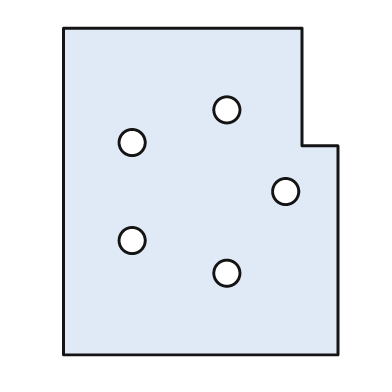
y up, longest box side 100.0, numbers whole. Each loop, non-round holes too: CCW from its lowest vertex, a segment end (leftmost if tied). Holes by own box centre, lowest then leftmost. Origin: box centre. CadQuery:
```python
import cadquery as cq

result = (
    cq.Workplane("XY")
    .moveTo(-42.0, -50.0)
    .lineTo(42.0, -50.0)
    .lineTo(42.0, 14.0)
    .lineTo(31.0, 14.0)
    .lineTo(31.0, 50.0)
    .lineTo(-42.0, 50.0)
    .close()
    .moveTo(8.0, -25.0)
    .circle(4.0)
    .moveTo(-21.0, -15.0)
    .circle(4.0)
    .moveTo(26.0, 0.0)
    .circle(4.0)
    .moveTo(-21.0, 15.0)
    .circle(4.0)
    .moveTo(8.0, 25.0)
    .circle(4.0)
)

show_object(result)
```